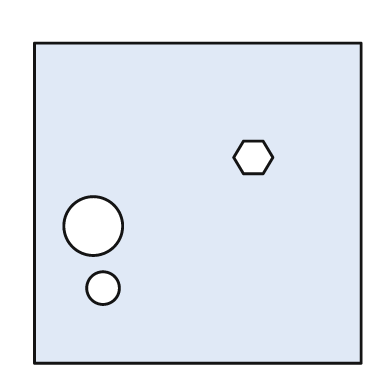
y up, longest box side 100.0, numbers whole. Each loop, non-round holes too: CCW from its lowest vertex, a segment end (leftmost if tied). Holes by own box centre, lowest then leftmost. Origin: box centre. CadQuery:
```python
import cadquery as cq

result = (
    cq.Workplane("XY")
    .moveTo(-50.0, -49.0)
    .lineTo(50.0, -49.0)
    .lineTo(50.0, 49.0)
    .lineTo(-50.0, 49.0)
    .close()
    .moveTo(-29.0, -26.0)
    .circle(5.0)
    .moveTo(-32.0, -7.0)
    .circle(9.0)
    .moveTo(14.0, 9.0)
    .lineTo(20.0, 9.0)
    .lineTo(23.0, 14.0)
    .lineTo(20.0, 19.0)
    .lineTo(14.0, 19.0)
    .lineTo(11.0, 14.0)
    .close()
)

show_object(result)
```